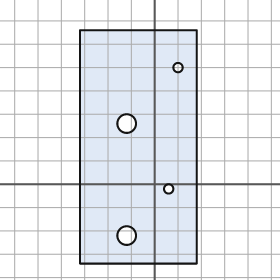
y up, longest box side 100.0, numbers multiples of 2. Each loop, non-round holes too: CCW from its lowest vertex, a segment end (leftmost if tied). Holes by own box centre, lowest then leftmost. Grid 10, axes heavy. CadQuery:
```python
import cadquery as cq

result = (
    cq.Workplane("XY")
    .moveTo(-32.0, -34.0)
    .lineTo(18.0, -34.0)
    .lineTo(18.0, 66.0)
    .lineTo(-32.0, 66.0)
    .close()
    .moveTo(-12.0, -22.0)
    .circle(4.0)
    .moveTo(6.0, -2.0)
    .circle(2.0)
    .moveTo(-12.0, 26.0)
    .circle(4.0)
    .moveTo(10.0, 50.0)
    .circle(2.0)
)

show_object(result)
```